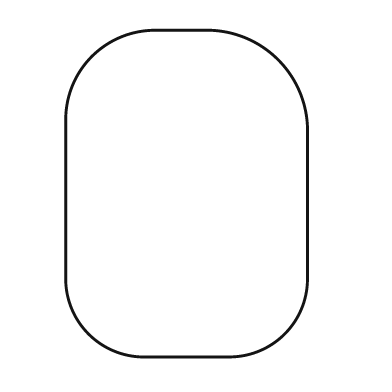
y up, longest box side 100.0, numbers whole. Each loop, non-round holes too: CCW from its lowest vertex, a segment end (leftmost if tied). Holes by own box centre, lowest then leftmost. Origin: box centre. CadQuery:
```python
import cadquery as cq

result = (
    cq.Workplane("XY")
    .moveTo(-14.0, -50.0)
    .lineTo(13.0, -50.0)
    .threePointArc((30.0, -43.0), (37.0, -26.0))
    .lineTo(37.0, 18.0)
    .threePointArc((28.0, 41.0), (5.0, 50.0))
    .lineTo(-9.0, 50.0)
    .threePointArc((-29.0, 42.0), (-37.0, 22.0))
    .lineTo(-37.0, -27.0)
    .threePointArc((-30.0, -43.0), (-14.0, -50.0))
    .close()
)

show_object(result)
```